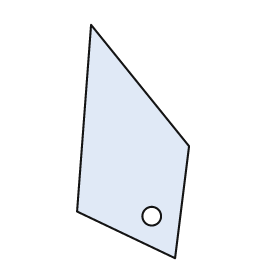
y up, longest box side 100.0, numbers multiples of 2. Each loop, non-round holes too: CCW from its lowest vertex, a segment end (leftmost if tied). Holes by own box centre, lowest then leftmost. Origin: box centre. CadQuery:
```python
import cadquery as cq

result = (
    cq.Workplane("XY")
    .moveTo(18.0, -50.0)
    .lineTo(24.0, -2.0)
    .lineTo(-18.0, 50.0)
    .lineTo(-24.0, -30.0)
    .close()
    .moveTo(8.0, -32.0)
    .circle(4.0)
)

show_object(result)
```